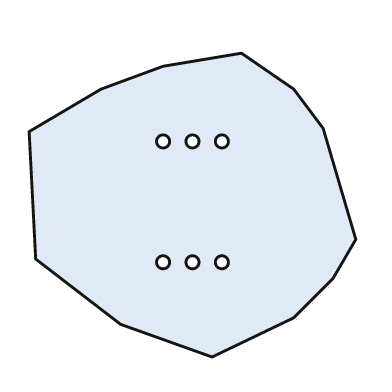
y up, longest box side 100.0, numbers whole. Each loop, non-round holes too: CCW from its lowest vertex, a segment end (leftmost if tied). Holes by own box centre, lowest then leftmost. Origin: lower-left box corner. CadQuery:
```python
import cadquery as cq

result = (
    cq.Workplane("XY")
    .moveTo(56.0, 0.0)
    .lineTo(81.0, 12.0)
    .lineTo(93.0, 24.0)
    .lineTo(100.0, 36.0)
    .lineTo(90.0, 70.0)
    .lineTo(81.0, 82.0)
    .lineTo(65.0, 93.0)
    .lineTo(41.0, 89.0)
    .lineTo(22.0, 82.0)
    .lineTo(0.0, 69.0)
    .lineTo(2.0, 30.0)
    .lineTo(28.0, 10.0)
    .close()
    .moveTo(41.0, 29.0)
    .circle(2.0)
    .moveTo(50.0, 29.0)
    .circle(2.0)
    .moveTo(59.0, 29.0)
    .circle(2.0)
    .moveTo(41.0, 66.0)
    .circle(2.0)
    .moveTo(50.0, 66.0)
    .circle(2.0)
    .moveTo(59.0, 66.0)
    .circle(2.0)
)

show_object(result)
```